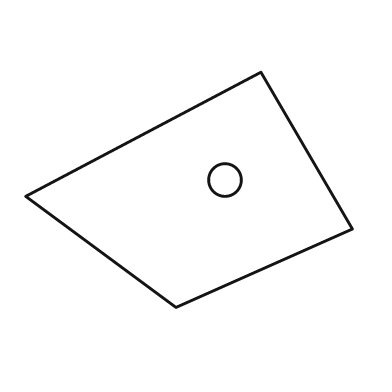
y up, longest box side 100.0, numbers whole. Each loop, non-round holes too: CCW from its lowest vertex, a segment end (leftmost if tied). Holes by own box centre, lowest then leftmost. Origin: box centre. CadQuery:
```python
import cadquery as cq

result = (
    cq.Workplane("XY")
    .moveTo(-4.0, -36.0)
    .lineTo(50.0, -12.0)
    .lineTo(22.0, 36.0)
    .lineTo(-50.0, -2.0)
    .close()
    .moveTo(11.0, 3.0)
    .circle(5.0)
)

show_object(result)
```